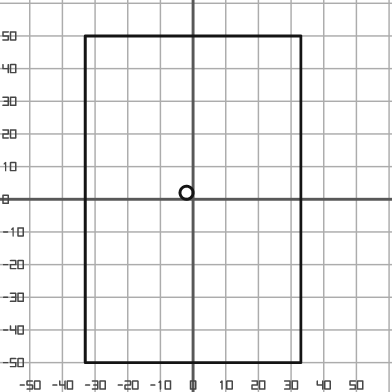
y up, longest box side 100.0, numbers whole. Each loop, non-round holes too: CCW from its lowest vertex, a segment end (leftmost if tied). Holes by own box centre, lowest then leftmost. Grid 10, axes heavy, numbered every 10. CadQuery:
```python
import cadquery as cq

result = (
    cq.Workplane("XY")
    .moveTo(-33.0, -50.0)
    .lineTo(33.0, -50.0)
    .lineTo(33.0, 50.0)
    .lineTo(-33.0, 50.0)
    .close()
    .moveTo(-2.0, 2.0)
    .circle(2.0)
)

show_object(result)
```